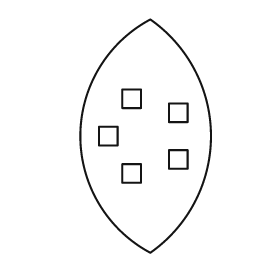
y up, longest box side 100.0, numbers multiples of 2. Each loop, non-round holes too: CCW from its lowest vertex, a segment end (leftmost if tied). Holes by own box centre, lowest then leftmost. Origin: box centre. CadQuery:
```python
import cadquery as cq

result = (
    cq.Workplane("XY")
    .moveTo(2.0, -50.0)
    .threePointArc((28.0, 0.0), (2.0, 50.0))
    .threePointArc((-28.0, 0.0), (2.0, -50.0))
    .close()
    .moveTo(-10.0, -20.0)
    .lineTo(-2.0, -20.0)
    .lineTo(-2.0, -12.0)
    .lineTo(-10.0, -12.0)
    .close()
    .moveTo(10.0, -14.0)
    .lineTo(18.0, -14.0)
    .lineTo(18.0, -6.0)
    .lineTo(10.0, -6.0)
    .close()
    .moveTo(-20.0, -4.0)
    .lineTo(-12.0, -4.0)
    .lineTo(-12.0, 4.0)
    .lineTo(-20.0, 4.0)
    .close()
    .moveTo(10.0, 6.0)
    .lineTo(18.0, 6.0)
    .lineTo(18.0, 14.0)
    .lineTo(10.0, 14.0)
    .close()
    .moveTo(-10.0, 12.0)
    .lineTo(-2.0, 12.0)
    .lineTo(-2.0, 20.0)
    .lineTo(-10.0, 20.0)
    .close()
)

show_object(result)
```